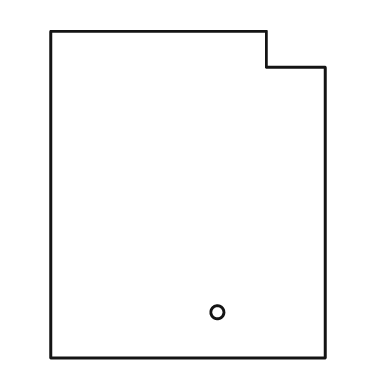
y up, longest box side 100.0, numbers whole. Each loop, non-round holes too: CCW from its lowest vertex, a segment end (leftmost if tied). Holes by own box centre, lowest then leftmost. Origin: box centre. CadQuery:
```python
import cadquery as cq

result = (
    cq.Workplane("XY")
    .moveTo(-42.0, -50.0)
    .lineTo(42.0, -50.0)
    .lineTo(42.0, 39.0)
    .lineTo(24.0, 39.0)
    .lineTo(24.0, 50.0)
    .lineTo(-42.0, 50.0)
    .close()
    .moveTo(9.0, -36.0)
    .circle(2.0)
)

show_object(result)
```